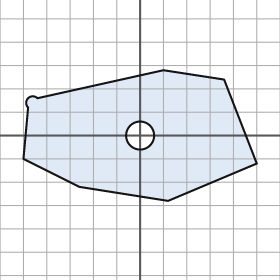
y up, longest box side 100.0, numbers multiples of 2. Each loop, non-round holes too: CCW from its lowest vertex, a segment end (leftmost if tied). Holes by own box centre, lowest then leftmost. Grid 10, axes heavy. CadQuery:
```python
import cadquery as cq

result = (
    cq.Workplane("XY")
    .moveTo(12.0, -28.0)
    .lineTo(50.0, -12.0)
    .lineTo(36.0, 24.0)
    .lineTo(10.0, 28.0)
    .lineTo(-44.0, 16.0)
    .threePointArc((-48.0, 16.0), (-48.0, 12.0))
    .lineTo(-50.0, -10.0)
    .lineTo(-26.0, -22.0)
    .close()
    .moveTo(0.0, 0.0)
    .circle(6.0)
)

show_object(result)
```